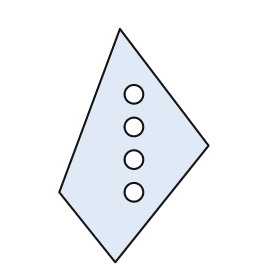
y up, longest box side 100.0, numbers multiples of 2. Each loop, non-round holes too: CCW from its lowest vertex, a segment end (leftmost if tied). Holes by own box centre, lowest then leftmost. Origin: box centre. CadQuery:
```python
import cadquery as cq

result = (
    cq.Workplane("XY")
    .moveTo(-8.0, -50.0)
    .lineTo(32.0, 0.0)
    .lineTo(-6.0, 50.0)
    .lineTo(-32.0, -20.0)
    .close()
    .moveTo(0.0, -20.0)
    .circle(4.0)
    .moveTo(0.0, -6.0)
    .circle(4.0)
    .moveTo(0.0, 8.0)
    .circle(4.0)
    .moveTo(0.0, 22.0)
    .circle(4.0)
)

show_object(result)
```